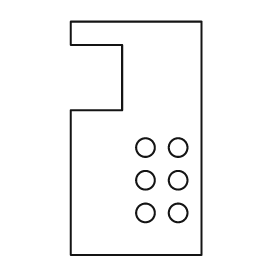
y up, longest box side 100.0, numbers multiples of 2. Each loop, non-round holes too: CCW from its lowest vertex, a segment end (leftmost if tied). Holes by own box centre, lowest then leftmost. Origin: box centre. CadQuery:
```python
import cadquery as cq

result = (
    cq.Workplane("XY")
    .moveTo(-28.0, -50.0)
    .lineTo(28.0, -50.0)
    .lineTo(28.0, 50.0)
    .lineTo(-28.0, 50.0)
    .lineTo(-28.0, 40.0)
    .lineTo(-6.0, 40.0)
    .lineTo(-6.0, 12.0)
    .lineTo(-28.0, 12.0)
    .close()
    .moveTo(4.0, -32.0)
    .circle(4.0)
    .moveTo(18.0, -32.0)
    .circle(4.0)
    .moveTo(4.0, -18.0)
    .circle(4.0)
    .moveTo(18.0, -18.0)
    .circle(4.0)
    .moveTo(4.0, -4.0)
    .circle(4.0)
    .moveTo(18.0, -4.0)
    .circle(4.0)
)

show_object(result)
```